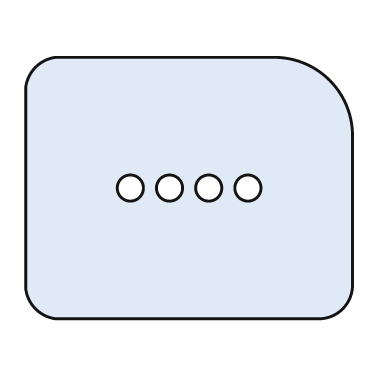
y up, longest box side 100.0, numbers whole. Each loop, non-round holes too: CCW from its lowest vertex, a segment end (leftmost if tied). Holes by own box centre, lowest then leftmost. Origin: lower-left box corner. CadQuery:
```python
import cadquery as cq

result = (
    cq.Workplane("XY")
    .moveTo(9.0, 0.0)
    .lineTo(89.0, 0.0)
    .threePointArc((97.0, 3.0), (100.0, 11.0))
    .lineTo(100.0, 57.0)
    .threePointArc((93.0, 73.0), (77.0, 80.0))
    .lineTo(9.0, 80.0)
    .threePointArc((3.0, 77.0), (0.0, 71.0))
    .lineTo(0.0, 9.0)
    .threePointArc((3.0, 3.0), (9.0, 0.0))
    .close()
    .moveTo(32.0, 40.0)
    .circle(4.0)
    .moveTo(44.0, 40.0)
    .circle(4.0)
    .moveTo(56.0, 40.0)
    .circle(4.0)
    .moveTo(68.0, 40.0)
    .circle(4.0)
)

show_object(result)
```